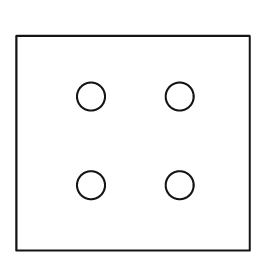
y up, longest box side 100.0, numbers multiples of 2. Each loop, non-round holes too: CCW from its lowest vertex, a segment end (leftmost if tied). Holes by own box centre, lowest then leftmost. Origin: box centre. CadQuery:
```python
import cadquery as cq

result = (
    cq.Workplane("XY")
    .moveTo(-50.0, -46.0)
    .lineTo(50.0, -46.0)
    .lineTo(50.0, 46.0)
    .lineTo(-50.0, 46.0)
    .close()
    .moveTo(-18.0, -18.0)
    .circle(6.0)
    .moveTo(20.0, -18.0)
    .circle(6.0)
    .moveTo(-18.0, 20.0)
    .circle(6.0)
    .moveTo(20.0, 20.0)
    .circle(6.0)
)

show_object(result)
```